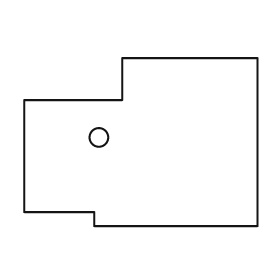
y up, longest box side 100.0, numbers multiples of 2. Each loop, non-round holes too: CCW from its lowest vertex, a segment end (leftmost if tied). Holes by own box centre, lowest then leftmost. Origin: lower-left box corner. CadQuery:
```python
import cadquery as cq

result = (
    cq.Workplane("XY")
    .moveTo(30.0, 0.0)
    .lineTo(100.0, 0.0)
    .lineTo(100.0, 72.0)
    .lineTo(42.0, 72.0)
    .lineTo(42.0, 54.0)
    .lineTo(0.0, 54.0)
    .lineTo(0.0, 6.0)
    .lineTo(30.0, 6.0)
    .close()
    .moveTo(32.0, 38.0)
    .circle(4.0)
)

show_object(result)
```